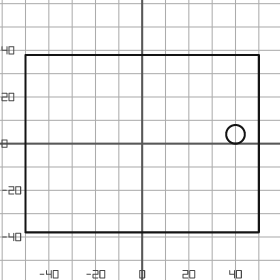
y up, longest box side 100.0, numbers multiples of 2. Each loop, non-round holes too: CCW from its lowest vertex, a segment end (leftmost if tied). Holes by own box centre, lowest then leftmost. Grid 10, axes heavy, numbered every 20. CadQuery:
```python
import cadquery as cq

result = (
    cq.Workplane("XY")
    .moveTo(-50.0, -38.0)
    .lineTo(50.0, -38.0)
    .lineTo(50.0, 38.0)
    .lineTo(-50.0, 38.0)
    .close()
    .moveTo(40.0, 4.0)
    .circle(4.0)
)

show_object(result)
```